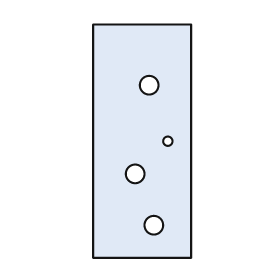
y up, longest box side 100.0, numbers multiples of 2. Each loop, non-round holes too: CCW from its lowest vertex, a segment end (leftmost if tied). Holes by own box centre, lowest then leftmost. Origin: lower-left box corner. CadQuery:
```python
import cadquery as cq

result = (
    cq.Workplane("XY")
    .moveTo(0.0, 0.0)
    .lineTo(42.0, 0.0)
    .lineTo(42.0, 100.0)
    .lineTo(0.0, 100.0)
    .close()
    .moveTo(26.0, 14.0)
    .circle(4.0)
    .moveTo(18.0, 36.0)
    .circle(4.0)
    .moveTo(32.0, 50.0)
    .circle(2.0)
    .moveTo(24.0, 74.0)
    .circle(4.0)
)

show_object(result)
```